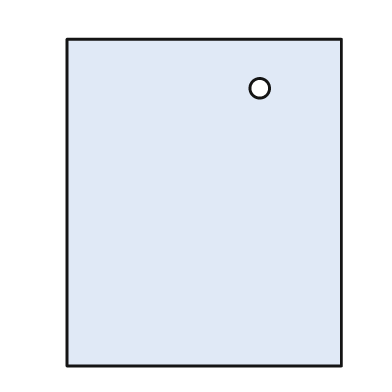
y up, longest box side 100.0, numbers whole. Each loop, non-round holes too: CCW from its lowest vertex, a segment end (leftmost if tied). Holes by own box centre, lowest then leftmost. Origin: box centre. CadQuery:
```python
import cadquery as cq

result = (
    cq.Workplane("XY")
    .moveTo(-42.0, -50.0)
    .lineTo(42.0, -50.0)
    .lineTo(42.0, 50.0)
    .lineTo(-42.0, 50.0)
    .close()
    .moveTo(17.0, 35.0)
    .circle(3.0)
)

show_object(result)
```